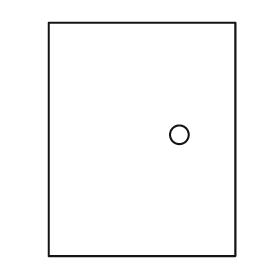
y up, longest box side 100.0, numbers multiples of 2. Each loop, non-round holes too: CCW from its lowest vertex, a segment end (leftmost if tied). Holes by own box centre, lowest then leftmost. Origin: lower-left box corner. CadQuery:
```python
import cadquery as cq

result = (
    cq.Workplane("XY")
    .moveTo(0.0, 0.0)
    .lineTo(80.0, 0.0)
    .lineTo(80.0, 100.0)
    .lineTo(0.0, 100.0)
    .close()
    .moveTo(56.0, 52.0)
    .circle(4.0)
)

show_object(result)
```